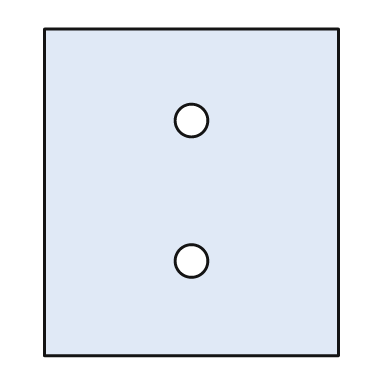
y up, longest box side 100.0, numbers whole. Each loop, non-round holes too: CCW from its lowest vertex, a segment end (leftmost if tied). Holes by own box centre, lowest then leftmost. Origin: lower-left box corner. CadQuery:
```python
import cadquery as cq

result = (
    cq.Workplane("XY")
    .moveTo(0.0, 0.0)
    .lineTo(90.0, 0.0)
    .lineTo(90.0, 100.0)
    .lineTo(0.0, 100.0)
    .close()
    .moveTo(45.0, 29.0)
    .circle(5.0)
    .moveTo(45.0, 72.0)
    .circle(5.0)
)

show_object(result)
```